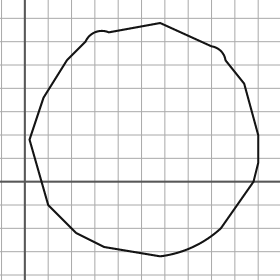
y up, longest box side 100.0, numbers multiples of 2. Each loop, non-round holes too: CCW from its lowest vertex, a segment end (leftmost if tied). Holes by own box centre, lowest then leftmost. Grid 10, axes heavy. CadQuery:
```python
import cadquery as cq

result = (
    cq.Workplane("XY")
    .moveTo(58.0, -32.0)
    .threePointArc((72.0, -28.0), (84.0, -20.0))
    .lineTo(98.0, 0.0)
    .lineTo(100.0, 8.0)
    .lineTo(100.0, 20.0)
    .lineTo(94.0, 42.0)
    .lineTo(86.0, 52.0)
    .threePointArc((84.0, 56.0), (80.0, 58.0))
    .lineTo(58.0, 68.0)
    .lineTo(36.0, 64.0)
    .threePointArc((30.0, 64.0), (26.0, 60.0))
    .lineTo(18.0, 52.0)
    .lineTo(8.0, 36.0)
    .lineTo(2.0, 18.0)
    .lineTo(10.0, -10.0)
    .lineTo(22.0, -22.0)
    .lineTo(34.0, -28.0)
    .close()
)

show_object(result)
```